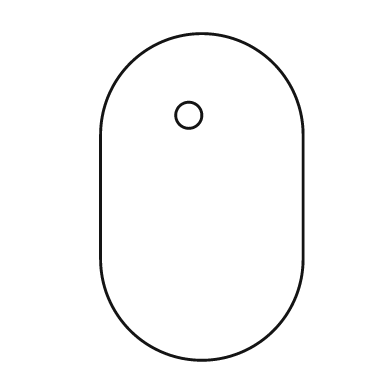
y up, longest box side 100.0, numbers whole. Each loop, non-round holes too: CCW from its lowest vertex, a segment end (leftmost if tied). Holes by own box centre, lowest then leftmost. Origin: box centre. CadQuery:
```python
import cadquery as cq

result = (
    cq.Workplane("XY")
    .moveTo(-31.0, -19.0)
    .threePointArc((0.0, -50.0), (31.0, -19.0))
    .lineTo(31.0, 19.0)
    .threePointArc((0.0, 50.0), (-31.0, 19.0))
    .close()
    .moveTo(-4.0, 25.0)
    .circle(4.0)
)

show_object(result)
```